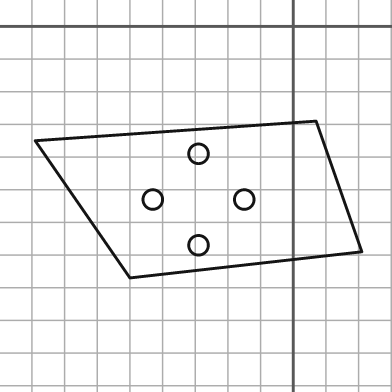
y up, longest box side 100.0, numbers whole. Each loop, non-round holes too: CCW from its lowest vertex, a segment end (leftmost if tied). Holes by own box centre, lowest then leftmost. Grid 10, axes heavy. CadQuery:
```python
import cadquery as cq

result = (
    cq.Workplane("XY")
    .moveTo(-50.0, -77.0)
    .lineTo(21.0, -69.0)
    .lineTo(7.0, -29.0)
    .lineTo(-79.0, -35.0)
    .close()
    .moveTo(-29.0, -67.0)
    .circle(3.0)
    .moveTo(-43.0, -53.0)
    .circle(3.0)
    .moveTo(-15.0, -53.0)
    .circle(3.0)
    .moveTo(-29.0, -39.0)
    .circle(3.0)
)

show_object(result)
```